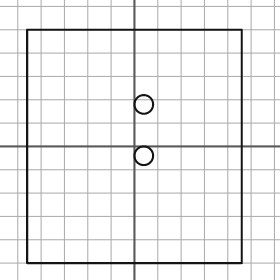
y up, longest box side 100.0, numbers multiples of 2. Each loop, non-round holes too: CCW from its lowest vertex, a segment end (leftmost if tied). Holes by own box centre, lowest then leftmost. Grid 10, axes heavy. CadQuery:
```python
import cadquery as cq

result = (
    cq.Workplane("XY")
    .moveTo(-46.0, -50.0)
    .lineTo(46.0, -50.0)
    .lineTo(46.0, 50.0)
    .lineTo(-46.0, 50.0)
    .close()
    .moveTo(4.0, -4.0)
    .circle(4.0)
    .moveTo(4.0, 18.0)
    .circle(4.0)
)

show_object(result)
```